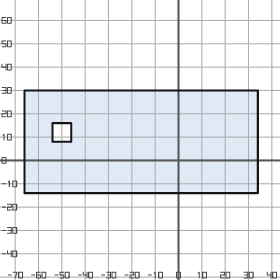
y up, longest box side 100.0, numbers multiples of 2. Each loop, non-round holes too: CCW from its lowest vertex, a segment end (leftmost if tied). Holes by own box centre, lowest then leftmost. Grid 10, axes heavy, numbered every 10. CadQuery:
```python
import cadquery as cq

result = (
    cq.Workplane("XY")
    .moveTo(-66.0, -14.0)
    .lineTo(34.0, -14.0)
    .lineTo(34.0, 30.0)
    .lineTo(-66.0, 30.0)
    .close()
    .moveTo(-54.0, 8.0)
    .lineTo(-46.0, 8.0)
    .lineTo(-46.0, 16.0)
    .lineTo(-54.0, 16.0)
    .close()
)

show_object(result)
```